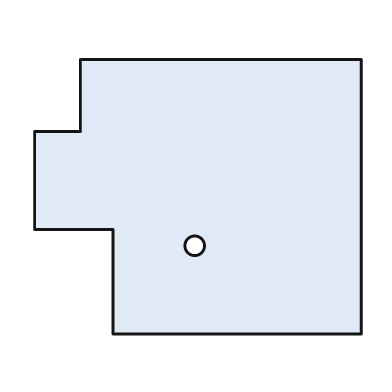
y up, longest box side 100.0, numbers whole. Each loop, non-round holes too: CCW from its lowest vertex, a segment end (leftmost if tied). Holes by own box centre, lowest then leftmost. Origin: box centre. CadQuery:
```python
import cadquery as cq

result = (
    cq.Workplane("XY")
    .moveTo(-26.0, -42.0)
    .lineTo(50.0, -42.0)
    .lineTo(50.0, 42.0)
    .lineTo(-36.0, 42.0)
    .lineTo(-36.0, 20.0)
    .lineTo(-50.0, 20.0)
    .lineTo(-50.0, -10.0)
    .lineTo(-26.0, -10.0)
    .close()
    .moveTo(-1.0, -15.0)
    .circle(3.0)
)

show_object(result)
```